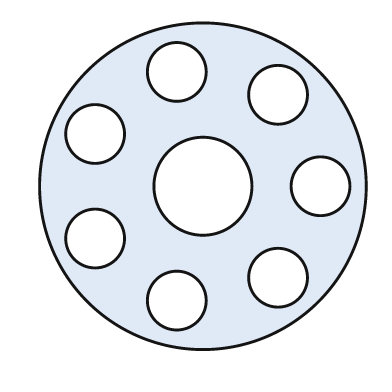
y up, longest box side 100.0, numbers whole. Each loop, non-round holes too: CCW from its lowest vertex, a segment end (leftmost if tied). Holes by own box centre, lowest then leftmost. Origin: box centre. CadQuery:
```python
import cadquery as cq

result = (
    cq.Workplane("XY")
    .moveTo(0.0, 0.0)
    .circle(50.0)
    .moveTo(-8.0, -35.0)
    .circle(9.0)
    .moveTo(23.0, -28.0)
    .circle(9.0)
    .moveTo(-33.0, -16.0)
    .circle(9.0)
    .moveTo(0.0, 0.0)
    .circle(15.0)
    .moveTo(36.0, 0.0)
    .circle(9.0)
    .moveTo(-33.0, 16.0)
    .circle(9.0)
    .moveTo(23.0, 28.0)
    .circle(9.0)
    .moveTo(-8.0, 35.0)
    .circle(9.0)
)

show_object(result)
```